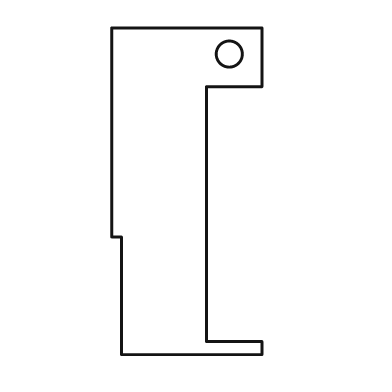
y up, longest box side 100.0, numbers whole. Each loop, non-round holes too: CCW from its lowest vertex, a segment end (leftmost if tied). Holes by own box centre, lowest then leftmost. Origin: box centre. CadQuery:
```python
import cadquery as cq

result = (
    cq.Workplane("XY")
    .moveTo(-20.0, -50.0)
    .lineTo(23.0, -50.0)
    .lineTo(23.0, -46.0)
    .lineTo(6.0, -46.0)
    .lineTo(6.0, 32.0)
    .lineTo(23.0, 32.0)
    .lineTo(23.0, 50.0)
    .lineTo(-23.0, 50.0)
    .lineTo(-23.0, -14.0)
    .lineTo(-20.0, -14.0)
    .close()
    .moveTo(13.0, 42.0)
    .circle(4.0)
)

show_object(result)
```